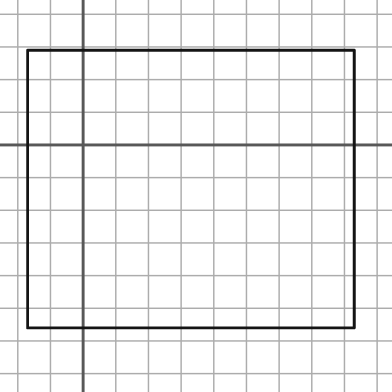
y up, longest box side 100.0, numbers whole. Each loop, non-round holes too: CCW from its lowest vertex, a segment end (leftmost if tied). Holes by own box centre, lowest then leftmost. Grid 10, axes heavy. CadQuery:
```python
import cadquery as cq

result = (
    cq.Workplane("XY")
    .moveTo(-17.0, -56.0)
    .lineTo(83.0, -56.0)
    .lineTo(83.0, 29.0)
    .lineTo(-17.0, 29.0)
    .close()
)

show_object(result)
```